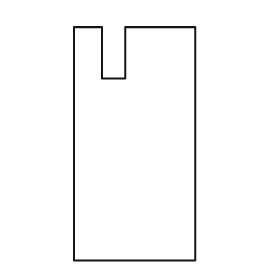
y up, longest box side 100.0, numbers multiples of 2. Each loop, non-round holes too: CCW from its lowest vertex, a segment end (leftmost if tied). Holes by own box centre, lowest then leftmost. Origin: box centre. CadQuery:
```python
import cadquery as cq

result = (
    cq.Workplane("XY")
    .moveTo(-26.0, -50.0)
    .lineTo(26.0, -50.0)
    .lineTo(26.0, 50.0)
    .lineTo(-4.0, 50.0)
    .lineTo(-4.0, 28.0)
    .lineTo(-14.0, 28.0)
    .lineTo(-14.0, 50.0)
    .lineTo(-26.0, 50.0)
    .close()
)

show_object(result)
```